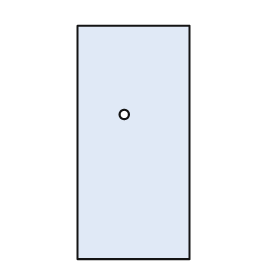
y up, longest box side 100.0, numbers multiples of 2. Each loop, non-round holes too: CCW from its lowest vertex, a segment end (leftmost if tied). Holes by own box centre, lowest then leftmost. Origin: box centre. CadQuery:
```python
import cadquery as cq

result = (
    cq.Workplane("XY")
    .moveTo(-24.0, -50.0)
    .lineTo(24.0, -50.0)
    .lineTo(24.0, 50.0)
    .lineTo(-24.0, 50.0)
    .close()
    .moveTo(-4.0, 12.0)
    .circle(2.0)
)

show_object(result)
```